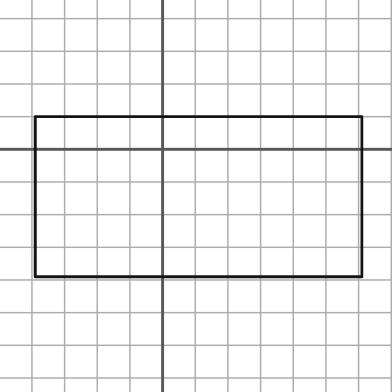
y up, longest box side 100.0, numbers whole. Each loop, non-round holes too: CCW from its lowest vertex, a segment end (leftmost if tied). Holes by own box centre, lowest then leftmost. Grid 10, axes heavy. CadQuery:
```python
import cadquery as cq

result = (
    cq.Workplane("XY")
    .moveTo(-39.0, -39.0)
    .lineTo(61.0, -39.0)
    .lineTo(61.0, 10.0)
    .lineTo(-39.0, 10.0)
    .close()
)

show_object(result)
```